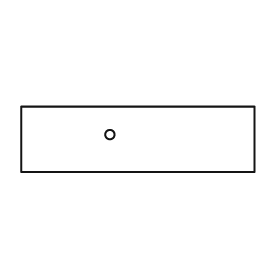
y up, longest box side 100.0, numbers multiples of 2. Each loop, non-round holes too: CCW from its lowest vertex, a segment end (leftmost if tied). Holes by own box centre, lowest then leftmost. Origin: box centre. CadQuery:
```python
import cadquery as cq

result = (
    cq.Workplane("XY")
    .moveTo(-50.0, -14.0)
    .lineTo(50.0, -14.0)
    .lineTo(50.0, 14.0)
    .lineTo(-50.0, 14.0)
    .close()
    .moveTo(-12.0, 2.0)
    .circle(2.0)
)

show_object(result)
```